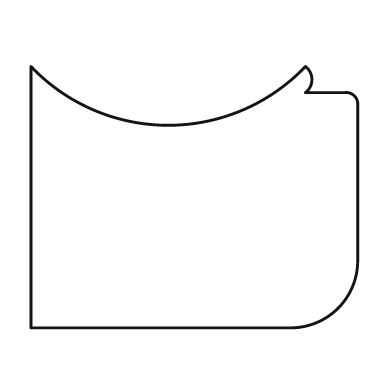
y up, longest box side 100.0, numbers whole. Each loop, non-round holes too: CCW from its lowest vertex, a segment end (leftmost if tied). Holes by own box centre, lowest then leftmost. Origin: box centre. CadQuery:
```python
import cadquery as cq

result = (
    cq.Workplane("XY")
    .moveTo(-50.0, -40.0)
    .lineTo(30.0, -40.0)
    .threePointArc((44.0, -34.0), (50.0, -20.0))
    .lineTo(50.0, 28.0)
    .threePointArc((49.0, 31.0), (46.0, 32.0))
    .lineTo(34.0, 32.0)
    .threePointArc((36.0, 36.0), (34.0, 40.0))
    .threePointArc((-8.0, 22.0), (-50.0, 40.0))
    .close()
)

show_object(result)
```